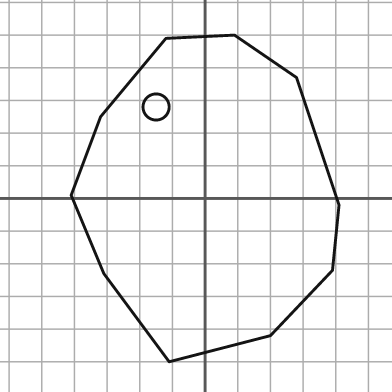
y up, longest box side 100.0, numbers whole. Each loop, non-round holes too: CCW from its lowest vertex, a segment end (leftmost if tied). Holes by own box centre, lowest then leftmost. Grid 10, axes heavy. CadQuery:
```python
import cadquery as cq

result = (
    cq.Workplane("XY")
    .moveTo(-11.0, -50.0)
    .lineTo(20.0, -42.0)
    .lineTo(39.0, -22.0)
    .lineTo(41.0, -2.0)
    .lineTo(28.0, 37.0)
    .lineTo(9.0, 50.0)
    .lineTo(-12.0, 49.0)
    .lineTo(-32.0, 25.0)
    .lineTo(-41.0, 1.0)
    .lineTo(-31.0, -23.0)
    .close()
    .moveTo(-15.0, 28.0)
    .circle(4.0)
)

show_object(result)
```